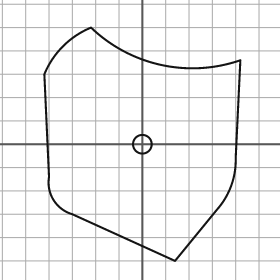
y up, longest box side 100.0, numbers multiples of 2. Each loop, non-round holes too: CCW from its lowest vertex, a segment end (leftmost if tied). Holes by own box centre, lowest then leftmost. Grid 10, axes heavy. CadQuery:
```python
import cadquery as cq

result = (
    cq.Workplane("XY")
    .moveTo(14.0, -50.0)
    .lineTo(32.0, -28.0)
    .threePointArc((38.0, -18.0), (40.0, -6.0))
    .lineTo(42.0, 36.0)
    .threePointArc((8.0, 34.0), (-22.0, 50.0))
    .threePointArc((-34.0, 42.0), (-42.0, 30.0))
    .lineTo(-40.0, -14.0)
    .threePointArc((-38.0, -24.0), (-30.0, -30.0))
    .close()
    .moveTo(0.0, 0.0)
    .circle(4.0)
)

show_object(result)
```